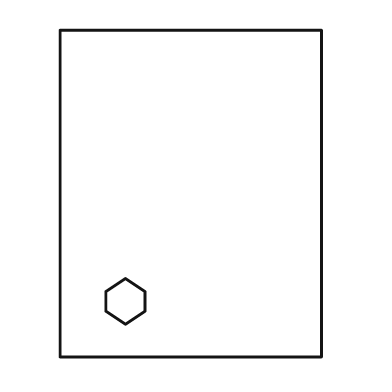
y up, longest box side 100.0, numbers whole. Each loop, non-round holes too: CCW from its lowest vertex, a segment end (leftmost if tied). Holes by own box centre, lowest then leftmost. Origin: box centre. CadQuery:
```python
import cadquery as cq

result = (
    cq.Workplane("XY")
    .moveTo(-40.0, -50.0)
    .lineTo(40.0, -50.0)
    .lineTo(40.0, 50.0)
    .lineTo(-40.0, 50.0)
    .close()
    .moveTo(-20.0, -40.0)
    .lineTo(-14.0, -36.0)
    .lineTo(-14.0, -30.0)
    .lineTo(-20.0, -26.0)
    .lineTo(-26.0, -30.0)
    .lineTo(-26.0, -36.0)
    .close()
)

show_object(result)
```